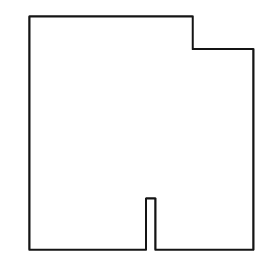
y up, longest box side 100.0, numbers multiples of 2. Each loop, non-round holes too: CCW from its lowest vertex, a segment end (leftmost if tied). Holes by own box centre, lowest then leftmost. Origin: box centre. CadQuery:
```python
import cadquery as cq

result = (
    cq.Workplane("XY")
    .moveTo(-48.0, -50.0)
    .lineTo(2.0, -50.0)
    .lineTo(2.0, -28.0)
    .lineTo(6.0, -28.0)
    .lineTo(6.0, -50.0)
    .lineTo(48.0, -50.0)
    .lineTo(48.0, 36.0)
    .lineTo(22.0, 36.0)
    .lineTo(22.0, 50.0)
    .lineTo(-48.0, 50.0)
    .close()
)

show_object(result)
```